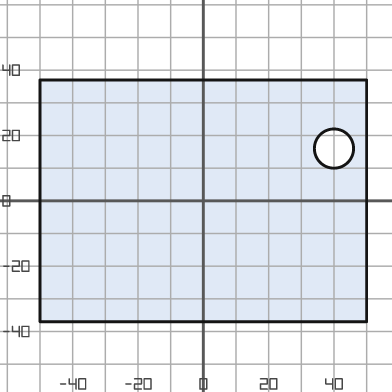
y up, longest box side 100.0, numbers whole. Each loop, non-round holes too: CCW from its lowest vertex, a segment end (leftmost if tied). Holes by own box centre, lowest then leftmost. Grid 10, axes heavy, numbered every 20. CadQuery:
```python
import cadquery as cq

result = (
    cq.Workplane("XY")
    .moveTo(-50.0, -37.0)
    .lineTo(50.0, -37.0)
    .lineTo(50.0, 37.0)
    .lineTo(-50.0, 37.0)
    .close()
    .moveTo(40.0, 16.0)
    .circle(6.0)
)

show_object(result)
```